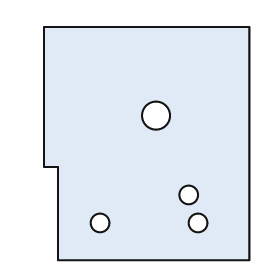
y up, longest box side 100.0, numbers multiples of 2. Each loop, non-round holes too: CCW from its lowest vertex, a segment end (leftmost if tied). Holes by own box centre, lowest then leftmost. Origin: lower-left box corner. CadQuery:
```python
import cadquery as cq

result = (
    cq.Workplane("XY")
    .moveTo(6.0, 0.0)
    .lineTo(88.0, 0.0)
    .lineTo(88.0, 100.0)
    .lineTo(0.0, 100.0)
    .lineTo(0.0, 40.0)
    .lineTo(6.0, 40.0)
    .close()
    .moveTo(24.0, 16.0)
    .circle(4.0)
    .moveTo(66.0, 16.0)
    .circle(4.0)
    .moveTo(62.0, 28.0)
    .circle(4.0)
    .moveTo(48.0, 62.0)
    .circle(6.0)
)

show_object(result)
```